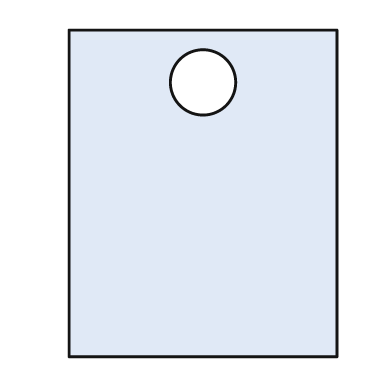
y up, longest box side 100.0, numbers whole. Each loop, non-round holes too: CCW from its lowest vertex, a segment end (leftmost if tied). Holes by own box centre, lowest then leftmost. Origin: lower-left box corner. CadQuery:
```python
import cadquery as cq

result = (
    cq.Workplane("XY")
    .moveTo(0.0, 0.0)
    .lineTo(82.0, 0.0)
    .lineTo(82.0, 100.0)
    .lineTo(0.0, 100.0)
    .close()
    .moveTo(41.0, 84.0)
    .circle(10.0)
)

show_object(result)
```